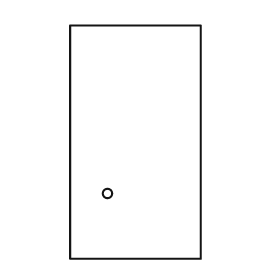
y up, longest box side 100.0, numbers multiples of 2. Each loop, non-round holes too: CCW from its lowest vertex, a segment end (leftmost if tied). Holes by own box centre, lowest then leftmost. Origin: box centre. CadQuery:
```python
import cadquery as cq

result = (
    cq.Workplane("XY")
    .moveTo(-28.0, -50.0)
    .lineTo(28.0, -50.0)
    .lineTo(28.0, 50.0)
    .lineTo(-28.0, 50.0)
    .close()
    .moveTo(-12.0, -22.0)
    .circle(2.0)
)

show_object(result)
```